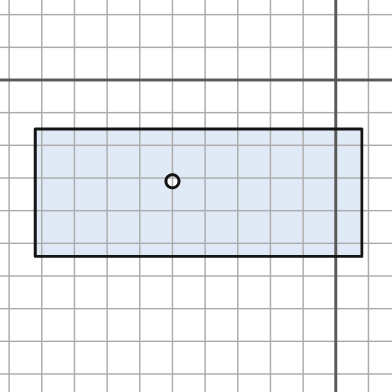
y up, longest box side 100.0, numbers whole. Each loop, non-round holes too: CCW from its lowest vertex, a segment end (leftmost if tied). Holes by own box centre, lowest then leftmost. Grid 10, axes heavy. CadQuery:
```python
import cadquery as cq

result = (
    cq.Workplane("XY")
    .moveTo(-92.0, -54.0)
    .lineTo(8.0, -54.0)
    .lineTo(8.0, -15.0)
    .lineTo(-92.0, -15.0)
    .close()
    .moveTo(-50.0, -31.0)
    .circle(2.0)
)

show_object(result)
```